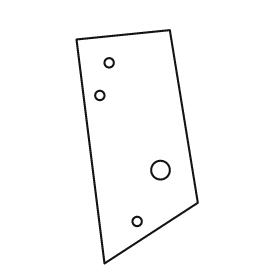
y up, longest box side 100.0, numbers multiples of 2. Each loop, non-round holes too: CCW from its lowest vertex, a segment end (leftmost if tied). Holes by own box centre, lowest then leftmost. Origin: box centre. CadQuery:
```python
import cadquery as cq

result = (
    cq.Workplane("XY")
    .moveTo(-14.0, -50.0)
    .lineTo(26.0, -24.0)
    .lineTo(14.0, 50.0)
    .lineTo(-26.0, 46.0)
    .close()
    .moveTo(0.0, -32.0)
    .circle(2.0)
    .moveTo(10.0, -10.0)
    .circle(4.0)
    .moveTo(-16.0, 22.0)
    .circle(2.0)
    .moveTo(-12.0, 36.0)
    .circle(2.0)
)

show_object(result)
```